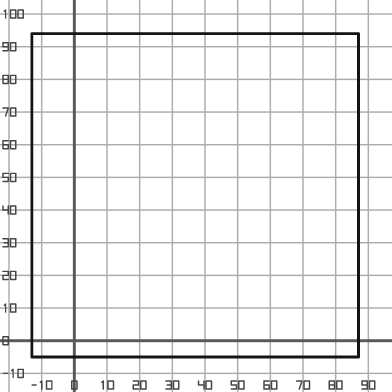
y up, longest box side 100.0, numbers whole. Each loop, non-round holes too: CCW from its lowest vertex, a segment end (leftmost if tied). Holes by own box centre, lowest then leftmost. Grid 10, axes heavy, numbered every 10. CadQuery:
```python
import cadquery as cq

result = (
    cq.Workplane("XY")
    .moveTo(-13.0, -5.0)
    .lineTo(87.0, -5.0)
    .lineTo(87.0, 94.0)
    .lineTo(-13.0, 94.0)
    .close()
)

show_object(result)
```